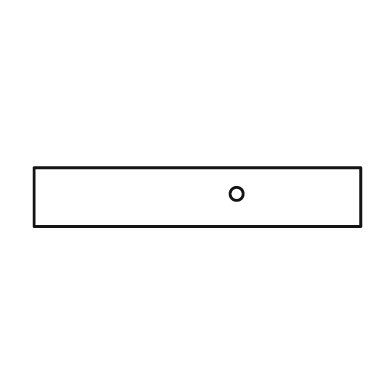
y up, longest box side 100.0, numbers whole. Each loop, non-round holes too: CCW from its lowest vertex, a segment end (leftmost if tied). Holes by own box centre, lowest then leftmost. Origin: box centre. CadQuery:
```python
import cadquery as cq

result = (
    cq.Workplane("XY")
    .moveTo(-50.0, -9.0)
    .lineTo(50.0, -9.0)
    .lineTo(50.0, 9.0)
    .lineTo(-50.0, 9.0)
    .close()
    .moveTo(12.0, 1.0)
    .circle(2.0)
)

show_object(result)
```